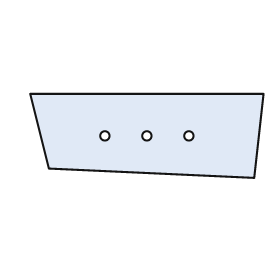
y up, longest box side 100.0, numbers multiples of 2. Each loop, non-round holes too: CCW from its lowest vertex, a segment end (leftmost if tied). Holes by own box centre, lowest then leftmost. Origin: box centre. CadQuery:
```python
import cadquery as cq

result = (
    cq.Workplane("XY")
    .moveTo(46.0, -18.0)
    .lineTo(50.0, 18.0)
    .lineTo(-50.0, 18.0)
    .lineTo(-42.0, -14.0)
    .close()
    .moveTo(-18.0, 0.0)
    .circle(2.0)
    .moveTo(0.0, 0.0)
    .circle(2.0)
    .moveTo(18.0, 0.0)
    .circle(2.0)
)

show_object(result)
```